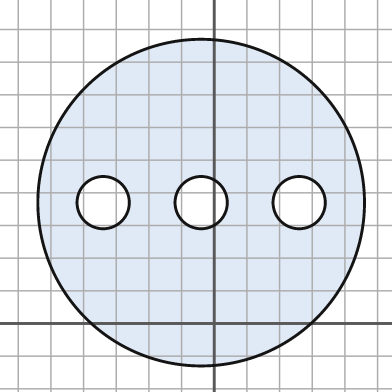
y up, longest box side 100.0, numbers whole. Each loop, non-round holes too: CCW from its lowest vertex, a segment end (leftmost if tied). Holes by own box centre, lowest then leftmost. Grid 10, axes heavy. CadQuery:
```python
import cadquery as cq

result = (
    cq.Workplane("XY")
    .moveTo(-4.0, 37.0)
    .circle(50.0)
    .moveTo(-34.0, 37.0)
    .circle(8.0)
    .moveTo(-4.0, 37.0)
    .circle(8.0)
    .moveTo(26.0, 37.0)
    .circle(8.0)
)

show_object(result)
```